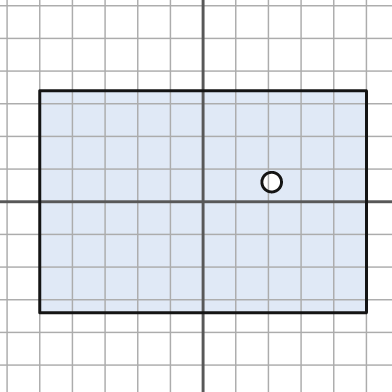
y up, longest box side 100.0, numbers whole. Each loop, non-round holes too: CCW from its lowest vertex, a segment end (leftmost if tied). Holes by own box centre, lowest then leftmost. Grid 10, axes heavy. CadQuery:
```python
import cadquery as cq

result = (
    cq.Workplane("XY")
    .moveTo(-50.0, -34.0)
    .lineTo(50.0, -34.0)
    .lineTo(50.0, 34.0)
    .lineTo(-50.0, 34.0)
    .close()
    .moveTo(21.0, 6.0)
    .circle(3.0)
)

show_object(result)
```